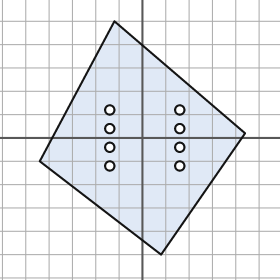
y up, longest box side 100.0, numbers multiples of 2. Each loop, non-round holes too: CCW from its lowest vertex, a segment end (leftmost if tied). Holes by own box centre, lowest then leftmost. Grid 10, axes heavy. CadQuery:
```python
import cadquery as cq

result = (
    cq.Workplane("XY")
    .moveTo(8.0, -50.0)
    .lineTo(44.0, 2.0)
    .lineTo(-12.0, 50.0)
    .lineTo(-44.0, -10.0)
    .close()
    .moveTo(-14.0, -12.0)
    .circle(2.0)
    .moveTo(16.0, -12.0)
    .circle(2.0)
    .moveTo(-14.0, -4.0)
    .circle(2.0)
    .moveTo(16.0, -4.0)
    .circle(2.0)
    .moveTo(-14.0, 4.0)
    .circle(2.0)
    .moveTo(16.0, 4.0)
    .circle(2.0)
    .moveTo(-14.0, 12.0)
    .circle(2.0)
    .moveTo(16.0, 12.0)
    .circle(2.0)
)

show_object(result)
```